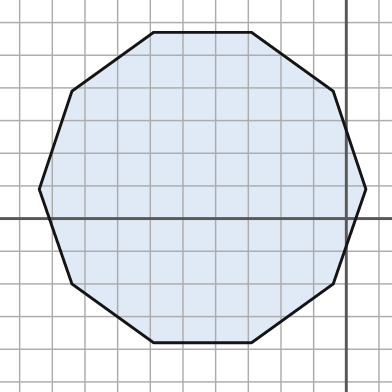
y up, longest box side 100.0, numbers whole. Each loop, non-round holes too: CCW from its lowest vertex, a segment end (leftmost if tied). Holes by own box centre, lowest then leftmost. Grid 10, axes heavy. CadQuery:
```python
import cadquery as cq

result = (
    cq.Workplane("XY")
    .moveTo(-59.0, -38.0)
    .lineTo(-29.0, -38.0)
    .lineTo(-4.0, -20.0)
    .lineTo(6.0, 9.0)
    .lineTo(-4.0, 39.0)
    .lineTo(-29.0, 57.0)
    .lineTo(-59.0, 57.0)
    .lineTo(-84.0, 39.0)
    .lineTo(-94.0, 9.0)
    .lineTo(-84.0, -20.0)
    .close()
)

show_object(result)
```